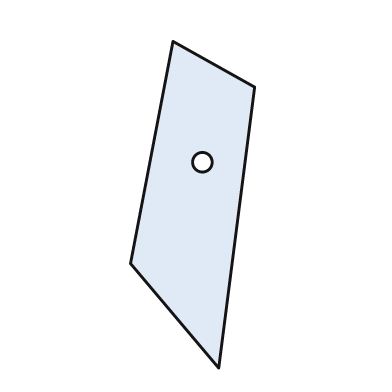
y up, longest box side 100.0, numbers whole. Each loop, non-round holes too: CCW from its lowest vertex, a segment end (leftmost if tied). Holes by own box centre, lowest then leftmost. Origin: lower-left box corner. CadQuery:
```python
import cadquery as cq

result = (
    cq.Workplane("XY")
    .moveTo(27.0, 0.0)
    .lineTo(38.0, 86.0)
    .lineTo(13.0, 100.0)
    .lineTo(0.0, 32.0)
    .close()
    .moveTo(22.0, 63.0)
    .circle(3.0)
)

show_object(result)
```